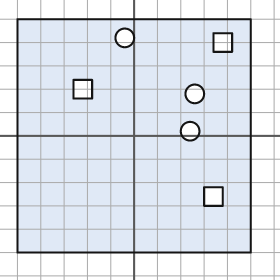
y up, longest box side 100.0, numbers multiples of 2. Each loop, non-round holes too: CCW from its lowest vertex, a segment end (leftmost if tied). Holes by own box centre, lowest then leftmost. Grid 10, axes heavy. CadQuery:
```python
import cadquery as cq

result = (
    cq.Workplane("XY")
    .moveTo(-50.0, -50.0)
    .lineTo(50.0, -50.0)
    .lineTo(50.0, 50.0)
    .lineTo(-50.0, 50.0)
    .close()
    .moveTo(30.0, -30.0)
    .lineTo(38.0, -30.0)
    .lineTo(38.0, -22.0)
    .lineTo(30.0, -22.0)
    .close()
    .moveTo(24.0, 2.0)
    .circle(4.0)
    .moveTo(26.0, 18.0)
    .circle(4.0)
    .moveTo(-26.0, 16.0)
    .lineTo(-18.0, 16.0)
    .lineTo(-18.0, 24.0)
    .lineTo(-26.0, 24.0)
    .close()
    .moveTo(34.0, 36.0)
    .lineTo(42.0, 36.0)
    .lineTo(42.0, 44.0)
    .lineTo(34.0, 44.0)
    .close()
    .moveTo(-4.0, 42.0)
    .circle(4.0)
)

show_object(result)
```